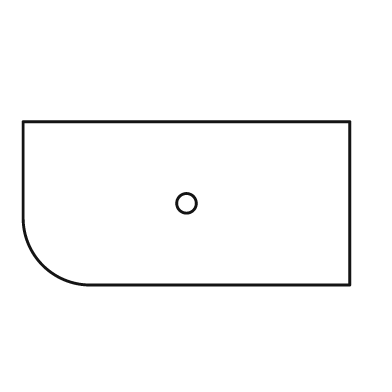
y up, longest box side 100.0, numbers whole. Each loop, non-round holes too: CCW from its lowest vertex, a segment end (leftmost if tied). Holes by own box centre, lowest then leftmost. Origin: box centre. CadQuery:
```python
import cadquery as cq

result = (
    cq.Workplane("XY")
    .moveTo(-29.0, -25.0)
    .lineTo(50.0, -25.0)
    .lineTo(50.0, 25.0)
    .lineTo(-50.0, 25.0)
    .lineTo(-50.0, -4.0)
    .threePointArc((-44.0, -19.0), (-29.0, -25.0))
    .close()
    .moveTo(0.0, 0.0)
    .circle(3.0)
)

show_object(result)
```